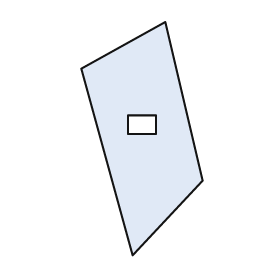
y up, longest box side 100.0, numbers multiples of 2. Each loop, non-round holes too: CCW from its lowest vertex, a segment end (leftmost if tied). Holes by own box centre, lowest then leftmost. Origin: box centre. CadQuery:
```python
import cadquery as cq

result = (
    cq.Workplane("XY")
    .moveTo(-4.0, -50.0)
    .lineTo(26.0, -18.0)
    .lineTo(10.0, 50.0)
    .lineTo(-26.0, 30.0)
    .close()
    .moveTo(-6.0, 2.0)
    .lineTo(6.0, 2.0)
    .lineTo(6.0, 10.0)
    .lineTo(-6.0, 10.0)
    .close()
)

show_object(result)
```